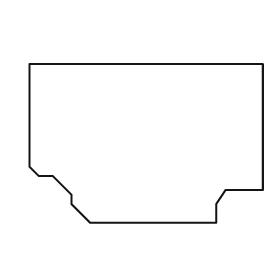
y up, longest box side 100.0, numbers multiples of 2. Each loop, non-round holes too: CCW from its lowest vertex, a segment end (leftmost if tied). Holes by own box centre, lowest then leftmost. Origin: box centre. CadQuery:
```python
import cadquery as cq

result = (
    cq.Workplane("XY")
    .moveTo(-24.0, -34.0)
    .lineTo(30.0, -34.0)
    .lineTo(30.0, -26.0)
    .lineTo(34.0, -20.0)
    .lineTo(50.0, -20.0)
    .lineTo(50.0, 34.0)
    .lineTo(-50.0, 34.0)
    .lineTo(-50.0, -10.0)
    .lineTo(-46.0, -14.0)
    .lineTo(-40.0, -14.0)
    .lineTo(-32.0, -22.0)
    .lineTo(-32.0, -26.0)
    .close()
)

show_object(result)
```